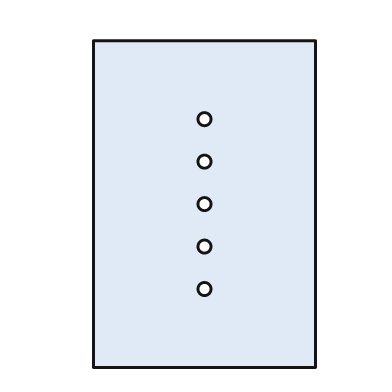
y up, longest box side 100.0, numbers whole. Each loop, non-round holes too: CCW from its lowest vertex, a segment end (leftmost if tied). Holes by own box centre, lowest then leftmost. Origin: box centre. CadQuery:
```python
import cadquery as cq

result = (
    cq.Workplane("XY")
    .moveTo(-34.0, -50.0)
    .lineTo(34.0, -50.0)
    .lineTo(34.0, 50.0)
    .lineTo(-34.0, 50.0)
    .close()
    .moveTo(0.0, -26.0)
    .circle(2.0)
    .moveTo(0.0, -13.0)
    .circle(2.0)
    .moveTo(0.0, 0.0)
    .circle(2.0)
    .moveTo(0.0, 13.0)
    .circle(2.0)
    .moveTo(0.0, 26.0)
    .circle(2.0)
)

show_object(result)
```